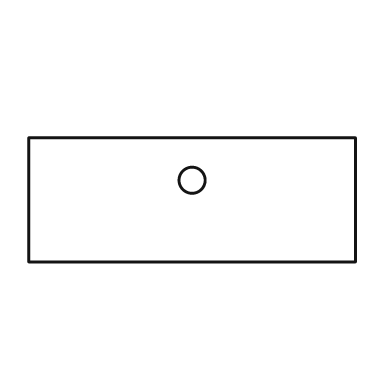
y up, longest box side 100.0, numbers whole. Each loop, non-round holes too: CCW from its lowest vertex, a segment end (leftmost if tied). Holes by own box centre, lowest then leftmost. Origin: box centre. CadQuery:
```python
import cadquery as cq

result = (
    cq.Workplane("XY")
    .moveTo(-50.0, -19.0)
    .lineTo(50.0, -19.0)
    .lineTo(50.0, 19.0)
    .lineTo(-50.0, 19.0)
    .close()
    .moveTo(0.0, 6.0)
    .circle(4.0)
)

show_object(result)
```